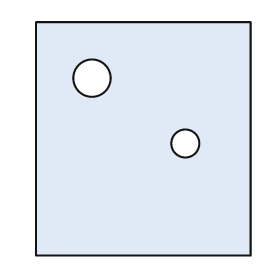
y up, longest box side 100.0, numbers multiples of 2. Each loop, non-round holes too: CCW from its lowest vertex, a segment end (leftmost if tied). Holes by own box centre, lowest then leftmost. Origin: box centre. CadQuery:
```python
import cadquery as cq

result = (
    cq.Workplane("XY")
    .moveTo(-46.0, -50.0)
    .lineTo(46.0, -50.0)
    .lineTo(46.0, 50.0)
    .lineTo(-46.0, 50.0)
    .close()
    .moveTo(18.0, -2.0)
    .circle(6.0)
    .moveTo(-22.0, 26.0)
    .circle(8.0)
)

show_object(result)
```